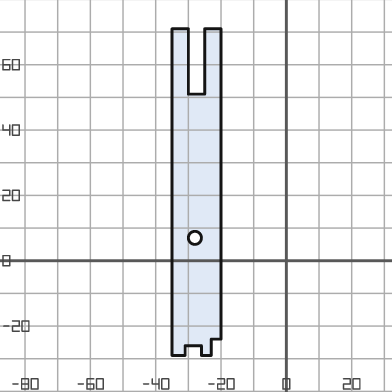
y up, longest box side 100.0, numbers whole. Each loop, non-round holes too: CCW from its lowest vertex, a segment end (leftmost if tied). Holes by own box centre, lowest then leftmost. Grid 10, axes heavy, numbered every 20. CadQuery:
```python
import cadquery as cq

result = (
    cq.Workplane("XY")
    .moveTo(-35.0, -29.0)
    .lineTo(-31.0, -29.0)
    .lineTo(-31.0, -26.0)
    .lineTo(-26.0, -26.0)
    .lineTo(-26.0, -29.0)
    .lineTo(-23.0, -29.0)
    .lineTo(-23.0, -24.0)
    .lineTo(-20.0, -24.0)
    .lineTo(-20.0, 71.0)
    .lineTo(-25.0, 71.0)
    .lineTo(-25.0, 51.0)
    .lineTo(-30.0, 51.0)
    .lineTo(-30.0, 71.0)
    .lineTo(-35.0, 71.0)
    .close()
    .moveTo(-28.0, 7.0)
    .circle(2.0)
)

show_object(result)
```